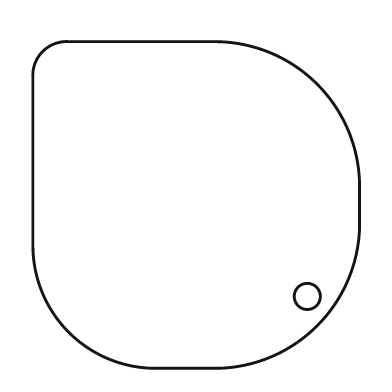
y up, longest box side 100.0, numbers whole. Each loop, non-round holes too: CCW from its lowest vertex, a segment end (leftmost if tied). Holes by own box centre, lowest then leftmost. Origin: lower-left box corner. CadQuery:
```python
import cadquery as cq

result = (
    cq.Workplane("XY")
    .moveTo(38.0, 0.0)
    .lineTo(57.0, 0.0)
    .threePointArc((87.0, 13.0), (100.0, 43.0))
    .lineTo(100.0, 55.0)
    .threePointArc((87.0, 87.0), (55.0, 100.0))
    .lineTo(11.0, 100.0)
    .threePointArc((3.0, 97.0), (0.0, 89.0))
    .lineTo(0.0, 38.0)
    .threePointArc((11.0, 11.0), (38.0, 0.0))
    .close()
    .moveTo(84.0, 22.0)
    .circle(4.0)
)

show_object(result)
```